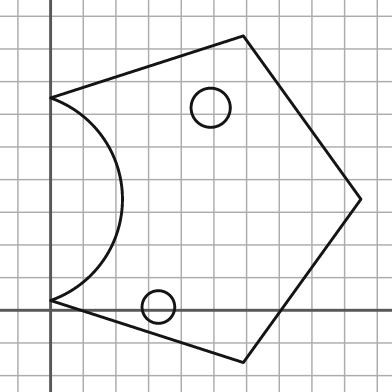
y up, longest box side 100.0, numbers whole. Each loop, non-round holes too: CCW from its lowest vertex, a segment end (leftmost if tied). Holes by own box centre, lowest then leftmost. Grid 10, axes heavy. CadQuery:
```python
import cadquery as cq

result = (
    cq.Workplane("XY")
    .moveTo(59.0, -16.0)
    .lineTo(95.0, 34.0)
    .lineTo(59.0, 84.0)
    .lineTo(0.0, 65.0)
    .threePointArc((22.0, 34.0), (0.0, 3.0))
    .close()
    .moveTo(33.0, 1.0)
    .circle(5.0)
    .moveTo(49.0, 62.0)
    .circle(6.0)
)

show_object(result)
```